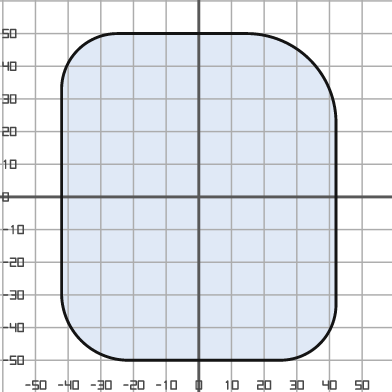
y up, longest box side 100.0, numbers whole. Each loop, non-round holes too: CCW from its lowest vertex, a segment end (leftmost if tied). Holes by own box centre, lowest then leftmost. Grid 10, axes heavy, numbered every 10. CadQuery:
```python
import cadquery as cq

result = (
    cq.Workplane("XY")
    .moveTo(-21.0, -50.0)
    .lineTo(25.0, -50.0)
    .threePointArc((37.0, -45.0), (42.0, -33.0))
    .lineTo(42.0, 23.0)
    .threePointArc((34.0, 42.0), (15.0, 50.0))
    .lineTo(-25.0, 50.0)
    .threePointArc((-37.0, 45.0), (-42.0, 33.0))
    .lineTo(-42.0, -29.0)
    .threePointArc((-36.0, -44.0), (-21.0, -50.0))
    .close()
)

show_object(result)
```